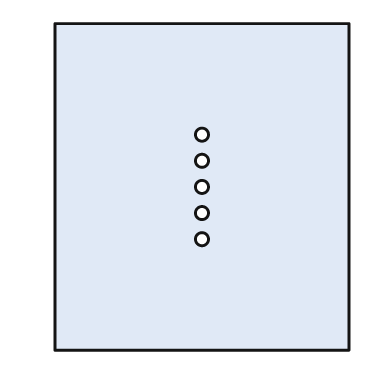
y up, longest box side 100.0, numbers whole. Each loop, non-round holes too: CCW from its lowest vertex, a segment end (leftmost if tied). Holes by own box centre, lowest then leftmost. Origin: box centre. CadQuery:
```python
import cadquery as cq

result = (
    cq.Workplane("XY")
    .moveTo(-45.0, -50.0)
    .lineTo(45.0, -50.0)
    .lineTo(45.0, 50.0)
    .lineTo(-45.0, 50.0)
    .close()
    .moveTo(0.0, -16.0)
    .circle(2.0)
    .moveTo(0.0, -8.0)
    .circle(2.0)
    .moveTo(0.0, 0.0)
    .circle(2.0)
    .moveTo(0.0, 8.0)
    .circle(2.0)
    .moveTo(0.0, 16.0)
    .circle(2.0)
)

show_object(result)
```